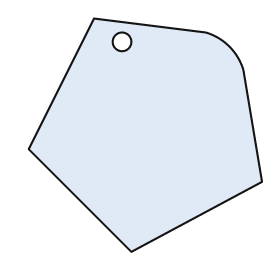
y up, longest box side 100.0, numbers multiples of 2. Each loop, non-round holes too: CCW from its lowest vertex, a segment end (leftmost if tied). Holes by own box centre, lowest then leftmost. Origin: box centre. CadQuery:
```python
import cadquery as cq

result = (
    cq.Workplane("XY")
    .moveTo(-6.0, -50.0)
    .lineTo(50.0, -20.0)
    .lineTo(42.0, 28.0)
    .threePointArc((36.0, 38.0), (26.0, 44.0))
    .lineTo(-22.0, 50.0)
    .lineTo(-50.0, -6.0)
    .close()
    .moveTo(-10.0, 40.0)
    .circle(4.0)
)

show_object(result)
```